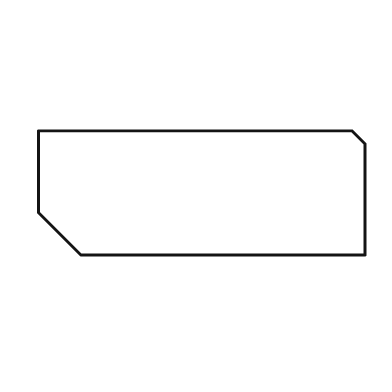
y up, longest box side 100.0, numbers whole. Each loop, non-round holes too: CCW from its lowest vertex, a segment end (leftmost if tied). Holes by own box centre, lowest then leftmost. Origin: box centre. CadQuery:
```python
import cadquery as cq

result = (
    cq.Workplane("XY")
    .moveTo(-37.0, -19.0)
    .lineTo(50.0, -19.0)
    .lineTo(50.0, 15.0)
    .lineTo(46.0, 19.0)
    .lineTo(-50.0, 19.0)
    .lineTo(-50.0, -6.0)
    .close()
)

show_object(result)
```